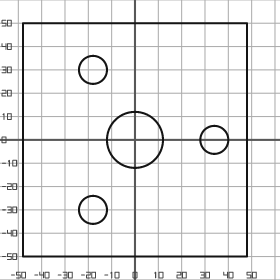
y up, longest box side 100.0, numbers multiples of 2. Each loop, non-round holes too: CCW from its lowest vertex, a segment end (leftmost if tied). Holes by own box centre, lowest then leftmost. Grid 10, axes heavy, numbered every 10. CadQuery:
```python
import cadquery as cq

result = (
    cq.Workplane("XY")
    .moveTo(-48.0, -50.0)
    .lineTo(48.0, -50.0)
    .lineTo(48.0, 50.0)
    .lineTo(-48.0, 50.0)
    .close()
    .moveTo(-18.0, -30.0)
    .circle(6.0)
    .moveTo(0.0, 0.0)
    .circle(12.0)
    .moveTo(34.0, 0.0)
    .circle(6.0)
    .moveTo(-18.0, 30.0)
    .circle(6.0)
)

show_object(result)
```